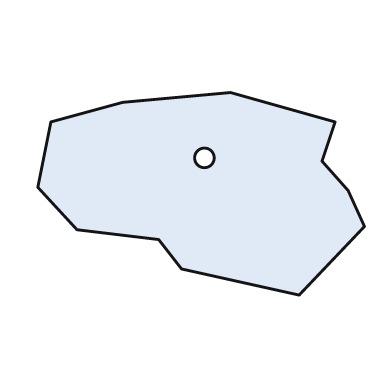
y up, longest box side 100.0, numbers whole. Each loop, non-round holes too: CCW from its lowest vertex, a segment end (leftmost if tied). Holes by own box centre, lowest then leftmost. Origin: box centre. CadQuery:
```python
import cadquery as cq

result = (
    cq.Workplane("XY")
    .moveTo(30.0, -31.0)
    .lineTo(50.0, -10.0)
    .lineTo(45.0, 1.0)
    .lineTo(37.0, 10.0)
    .lineTo(41.0, 22.0)
    .lineTo(9.0, 31.0)
    .lineTo(-24.0, 28.0)
    .lineTo(-46.0, 22.0)
    .lineTo(-50.0, 2.0)
    .lineTo(-38.0, -11.0)
    .lineTo(-13.0, -14.0)
    .lineTo(-6.0, -23.0)
    .close()
    .moveTo(1.0, 11.0)
    .circle(3.0)
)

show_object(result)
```